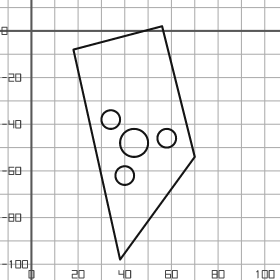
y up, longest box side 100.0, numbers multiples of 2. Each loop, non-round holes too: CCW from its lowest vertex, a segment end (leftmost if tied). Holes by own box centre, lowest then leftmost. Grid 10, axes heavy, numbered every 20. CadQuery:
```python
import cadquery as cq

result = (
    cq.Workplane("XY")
    .moveTo(38.0, -98.0)
    .lineTo(70.0, -54.0)
    .lineTo(56.0, 2.0)
    .lineTo(18.0, -8.0)
    .close()
    .moveTo(40.0, -62.0)
    .circle(4.0)
    .moveTo(44.0, -48.0)
    .circle(6.0)
    .moveTo(58.0, -46.0)
    .circle(4.0)
    .moveTo(34.0, -38.0)
    .circle(4.0)
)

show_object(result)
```